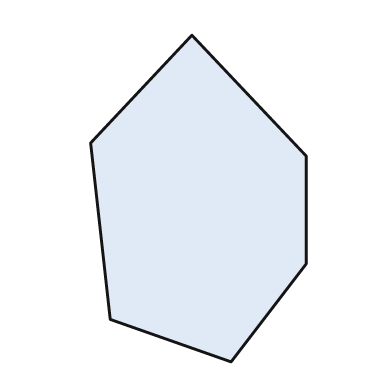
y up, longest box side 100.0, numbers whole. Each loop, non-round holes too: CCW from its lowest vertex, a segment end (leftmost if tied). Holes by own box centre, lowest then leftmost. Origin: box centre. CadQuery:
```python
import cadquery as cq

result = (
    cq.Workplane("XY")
    .moveTo(10.0, -50.0)
    .lineTo(33.0, -20.0)
    .lineTo(33.0, 13.0)
    .lineTo(-2.0, 50.0)
    .lineTo(-33.0, 17.0)
    .lineTo(-27.0, -37.0)
    .close()
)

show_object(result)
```